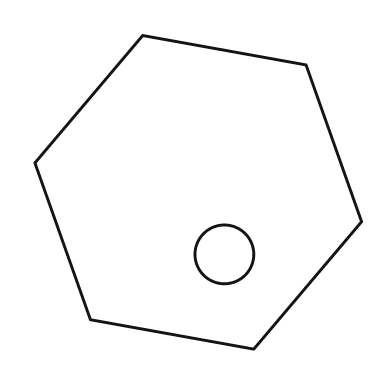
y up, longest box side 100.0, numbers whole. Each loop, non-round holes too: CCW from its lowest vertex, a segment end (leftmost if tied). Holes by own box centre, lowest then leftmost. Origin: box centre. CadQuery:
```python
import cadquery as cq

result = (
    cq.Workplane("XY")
    .moveTo(17.0, -48.0)
    .lineTo(50.0, -9.0)
    .lineTo(33.0, 39.0)
    .lineTo(-17.0, 48.0)
    .lineTo(-50.0, 9.0)
    .lineTo(-33.0, -39.0)
    .close()
    .moveTo(8.0, -19.0)
    .circle(9.0)
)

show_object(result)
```